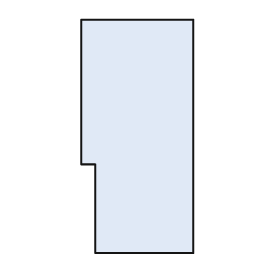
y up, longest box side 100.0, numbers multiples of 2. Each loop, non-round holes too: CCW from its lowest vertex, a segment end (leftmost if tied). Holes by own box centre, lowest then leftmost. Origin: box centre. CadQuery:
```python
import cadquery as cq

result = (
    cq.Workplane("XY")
    .moveTo(-18.0, -50.0)
    .lineTo(24.0, -50.0)
    .lineTo(24.0, 50.0)
    .lineTo(-24.0, 50.0)
    .lineTo(-24.0, -12.0)
    .lineTo(-18.0, -12.0)
    .close()
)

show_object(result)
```